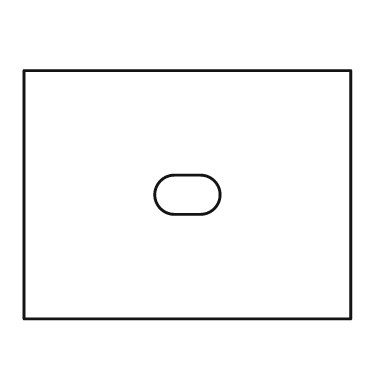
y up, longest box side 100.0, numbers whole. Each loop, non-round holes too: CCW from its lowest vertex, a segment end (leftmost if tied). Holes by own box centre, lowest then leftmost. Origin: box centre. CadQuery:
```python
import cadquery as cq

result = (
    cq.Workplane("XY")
    .moveTo(-50.0, -38.0)
    .lineTo(50.0, -38.0)
    .lineTo(50.0, 38.0)
    .lineTo(-50.0, 38.0)
    .close()
    .moveTo(-4.0, -6.0)
    .lineTo(4.0, -6.0)
    .threePointArc((10.0, 0.0), (4.0, 6.0))
    .lineTo(-4.0, 6.0)
    .threePointArc((-10.0, 0.0), (-4.0, -6.0))
    .close()
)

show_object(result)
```